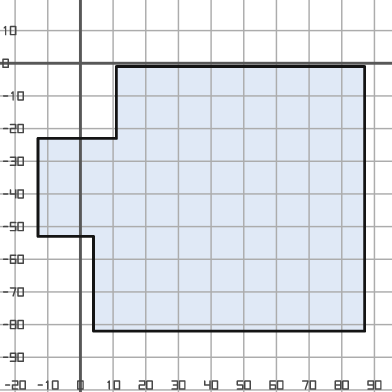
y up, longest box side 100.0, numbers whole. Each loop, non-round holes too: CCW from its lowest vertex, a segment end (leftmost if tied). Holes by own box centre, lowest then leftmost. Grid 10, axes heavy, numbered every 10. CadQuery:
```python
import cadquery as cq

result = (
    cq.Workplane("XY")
    .moveTo(4.0, -82.0)
    .lineTo(87.0, -82.0)
    .lineTo(87.0, -1.0)
    .lineTo(11.0, -1.0)
    .lineTo(11.0, -23.0)
    .lineTo(-13.0, -23.0)
    .lineTo(-13.0, -53.0)
    .lineTo(4.0, -53.0)
    .close()
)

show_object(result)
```